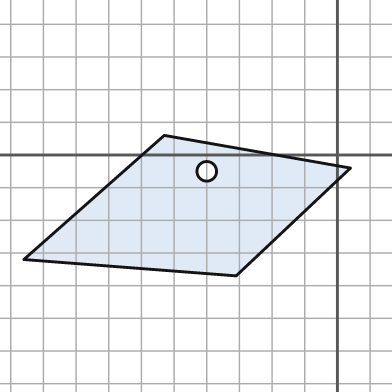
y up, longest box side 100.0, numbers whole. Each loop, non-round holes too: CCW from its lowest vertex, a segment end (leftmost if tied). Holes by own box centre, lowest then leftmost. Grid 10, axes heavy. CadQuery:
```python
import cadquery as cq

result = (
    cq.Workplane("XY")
    .moveTo(-31.0, -37.0)
    .lineTo(4.0, -4.0)
    .lineTo(-53.0, 6.0)
    .lineTo(-96.0, -32.0)
    .close()
    .moveTo(-40.0, -5.0)
    .circle(3.0)
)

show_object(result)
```